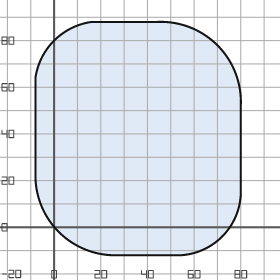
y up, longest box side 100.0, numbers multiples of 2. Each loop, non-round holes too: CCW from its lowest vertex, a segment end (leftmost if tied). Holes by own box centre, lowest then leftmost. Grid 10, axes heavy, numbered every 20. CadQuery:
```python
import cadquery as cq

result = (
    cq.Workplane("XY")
    .moveTo(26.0, -12.0)
    .lineTo(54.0, -12.0)
    .threePointArc((72.0, -4.0), (80.0, 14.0))
    .lineTo(80.0, 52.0)
    .threePointArc((70.0, 78.0), (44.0, 88.0))
    .lineTo(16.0, 88.0)
    .threePointArc((0.0, 80.0), (-8.0, 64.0))
    .lineTo(-8.0, 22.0)
    .threePointArc((2.0, -2.0), (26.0, -12.0))
    .close()
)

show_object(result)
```